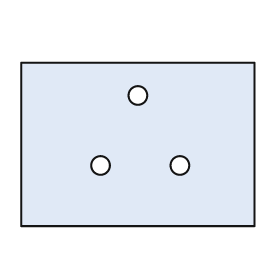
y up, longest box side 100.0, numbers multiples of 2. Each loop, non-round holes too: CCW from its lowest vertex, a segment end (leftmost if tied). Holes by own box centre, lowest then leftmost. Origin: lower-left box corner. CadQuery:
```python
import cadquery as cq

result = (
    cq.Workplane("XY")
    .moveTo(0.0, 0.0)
    .lineTo(100.0, 0.0)
    .lineTo(100.0, 70.0)
    .lineTo(0.0, 70.0)
    .close()
    .moveTo(34.0, 26.0)
    .circle(4.0)
    .moveTo(68.0, 26.0)
    .circle(4.0)
    .moveTo(50.0, 56.0)
    .circle(4.0)
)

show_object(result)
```